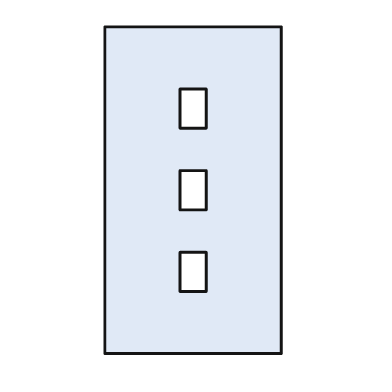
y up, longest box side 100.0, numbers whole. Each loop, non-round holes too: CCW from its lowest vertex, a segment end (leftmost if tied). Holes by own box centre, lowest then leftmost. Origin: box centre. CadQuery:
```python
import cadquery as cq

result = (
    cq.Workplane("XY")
    .moveTo(-27.0, -50.0)
    .lineTo(27.0, -50.0)
    .lineTo(27.0, 50.0)
    .lineTo(-27.0, 50.0)
    .close()
    .moveTo(-4.0, -31.0)
    .lineTo(4.0, -31.0)
    .lineTo(4.0, -19.0)
    .lineTo(-4.0, -19.0)
    .close()
    .moveTo(-4.0, -6.0)
    .lineTo(4.0, -6.0)
    .lineTo(4.0, 6.0)
    .lineTo(-4.0, 6.0)
    .close()
    .moveTo(-4.0, 19.0)
    .lineTo(4.0, 19.0)
    .lineTo(4.0, 31.0)
    .lineTo(-4.0, 31.0)
    .close()
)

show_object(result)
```